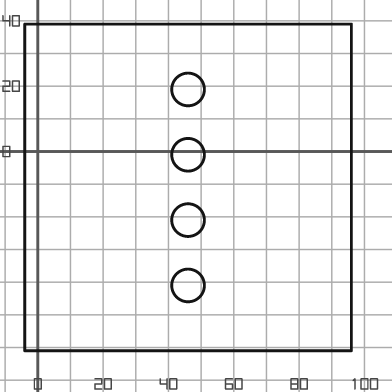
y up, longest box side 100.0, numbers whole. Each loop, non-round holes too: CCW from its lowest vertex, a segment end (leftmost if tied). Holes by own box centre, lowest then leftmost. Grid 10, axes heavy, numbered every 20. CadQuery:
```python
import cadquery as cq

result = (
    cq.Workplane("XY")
    .moveTo(-4.0, -61.0)
    .lineTo(96.0, -61.0)
    .lineTo(96.0, 39.0)
    .lineTo(-4.0, 39.0)
    .close()
    .moveTo(46.0, -41.0)
    .circle(5.0)
    .moveTo(46.0, -21.0)
    .circle(5.0)
    .moveTo(46.0, -1.0)
    .circle(5.0)
    .moveTo(46.0, 19.0)
    .circle(5.0)
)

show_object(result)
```